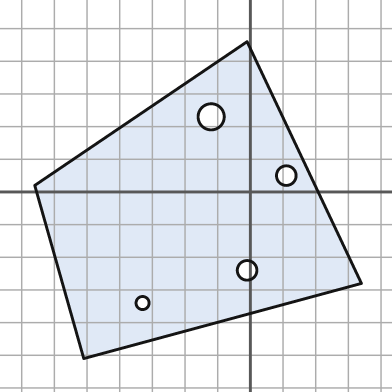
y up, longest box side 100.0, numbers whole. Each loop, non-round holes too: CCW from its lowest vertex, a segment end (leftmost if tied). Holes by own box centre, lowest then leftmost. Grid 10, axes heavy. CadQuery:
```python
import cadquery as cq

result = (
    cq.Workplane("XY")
    .moveTo(-51.0, -51.0)
    .lineTo(34.0, -28.0)
    .lineTo(-1.0, 46.0)
    .lineTo(-66.0, 2.0)
    .close()
    .moveTo(-33.0, -34.0)
    .circle(2.0)
    .moveTo(-1.0, -24.0)
    .circle(3.0)
    .moveTo(11.0, 5.0)
    .circle(3.0)
    .moveTo(-12.0, 23.0)
    .circle(4.0)
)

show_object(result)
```